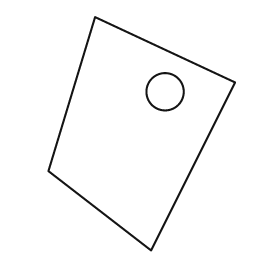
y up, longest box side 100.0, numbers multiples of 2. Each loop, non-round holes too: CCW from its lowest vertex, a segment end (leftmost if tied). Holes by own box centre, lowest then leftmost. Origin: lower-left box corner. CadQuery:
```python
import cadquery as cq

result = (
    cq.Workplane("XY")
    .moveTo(44.0, 0.0)
    .lineTo(80.0, 72.0)
    .lineTo(20.0, 100.0)
    .lineTo(0.0, 34.0)
    .close()
    .moveTo(50.0, 68.0)
    .circle(8.0)
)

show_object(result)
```